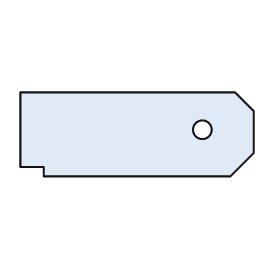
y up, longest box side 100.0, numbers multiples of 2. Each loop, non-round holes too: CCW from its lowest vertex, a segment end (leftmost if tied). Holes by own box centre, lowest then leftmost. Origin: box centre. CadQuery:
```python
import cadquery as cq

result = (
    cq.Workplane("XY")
    .moveTo(-40.0, -18.0)
    .lineTo(40.0, -18.0)
    .lineTo(50.0, -8.0)
    .lineTo(50.0, 10.0)
    .lineTo(42.0, 18.0)
    .lineTo(-50.0, 18.0)
    .lineTo(-50.0, -14.0)
    .lineTo(-40.0, -14.0)
    .close()
    .moveTo(28.0, 2.0)
    .circle(4.0)
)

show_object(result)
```